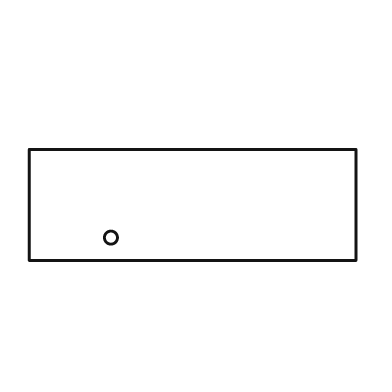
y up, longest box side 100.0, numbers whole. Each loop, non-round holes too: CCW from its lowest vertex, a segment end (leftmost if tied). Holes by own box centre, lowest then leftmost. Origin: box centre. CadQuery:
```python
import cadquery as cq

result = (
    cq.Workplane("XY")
    .moveTo(-50.0, -17.0)
    .lineTo(50.0, -17.0)
    .lineTo(50.0, 17.0)
    .lineTo(-50.0, 17.0)
    .close()
    .moveTo(-25.0, -10.0)
    .circle(2.0)
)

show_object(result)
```